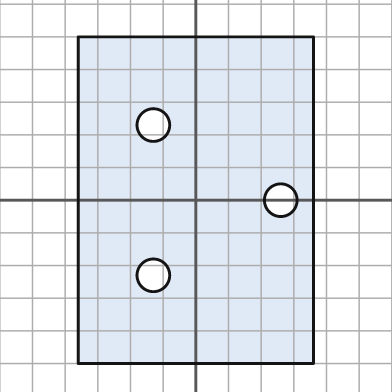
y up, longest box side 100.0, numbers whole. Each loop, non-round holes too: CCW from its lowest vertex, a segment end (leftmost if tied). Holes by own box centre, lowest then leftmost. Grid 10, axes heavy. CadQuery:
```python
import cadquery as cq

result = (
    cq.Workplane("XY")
    .moveTo(-36.0, -50.0)
    .lineTo(36.0, -50.0)
    .lineTo(36.0, 50.0)
    .lineTo(-36.0, 50.0)
    .close()
    .moveTo(-13.0, -23.0)
    .circle(5.0)
    .moveTo(26.0, 0.0)
    .circle(5.0)
    .moveTo(-13.0, 23.0)
    .circle(5.0)
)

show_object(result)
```